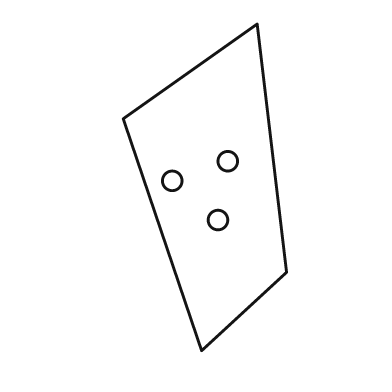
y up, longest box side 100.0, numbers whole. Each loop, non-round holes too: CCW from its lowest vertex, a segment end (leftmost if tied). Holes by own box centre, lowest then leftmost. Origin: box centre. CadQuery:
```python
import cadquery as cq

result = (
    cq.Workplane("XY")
    .moveTo(-1.0, -50.0)
    .lineTo(25.0, -26.0)
    .lineTo(16.0, 50.0)
    .lineTo(-25.0, 21.0)
    .close()
    .moveTo(4.0, -10.0)
    .circle(3.0)
    .moveTo(-10.0, 2.0)
    .circle(3.0)
    .moveTo(7.0, 8.0)
    .circle(3.0)
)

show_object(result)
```